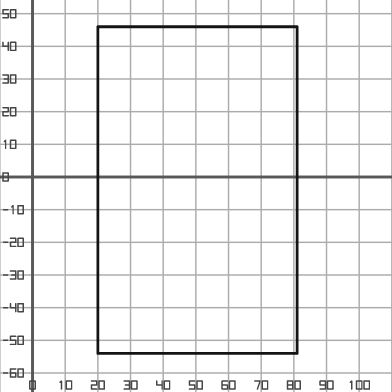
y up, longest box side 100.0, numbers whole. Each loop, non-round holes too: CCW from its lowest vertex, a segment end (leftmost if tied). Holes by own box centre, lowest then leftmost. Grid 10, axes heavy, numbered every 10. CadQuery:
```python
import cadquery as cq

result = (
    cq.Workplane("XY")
    .moveTo(20.0, -54.0)
    .lineTo(81.0, -54.0)
    .lineTo(81.0, 46.0)
    .lineTo(20.0, 46.0)
    .close()
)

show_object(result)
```